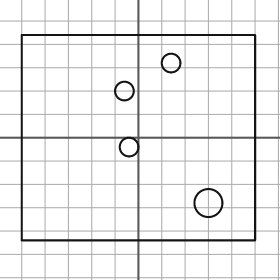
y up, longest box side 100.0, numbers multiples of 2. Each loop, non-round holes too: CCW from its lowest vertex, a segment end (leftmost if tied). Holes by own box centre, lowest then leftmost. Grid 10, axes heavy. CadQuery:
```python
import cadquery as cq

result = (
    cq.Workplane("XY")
    .moveTo(-50.0, -44.0)
    .lineTo(50.0, -44.0)
    .lineTo(50.0, 44.0)
    .lineTo(-50.0, 44.0)
    .close()
    .moveTo(30.0, -28.0)
    .circle(6.0)
    .moveTo(-4.0, -4.0)
    .circle(4.0)
    .moveTo(-6.0, 20.0)
    .circle(4.0)
    .moveTo(14.0, 32.0)
    .circle(4.0)
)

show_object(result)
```